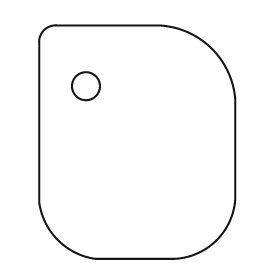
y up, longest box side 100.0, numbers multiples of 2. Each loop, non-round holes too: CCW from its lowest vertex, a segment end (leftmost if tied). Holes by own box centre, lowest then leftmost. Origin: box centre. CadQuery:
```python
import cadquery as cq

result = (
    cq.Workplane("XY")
    .moveTo(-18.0, -50.0)
    .lineTo(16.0, -50.0)
    .threePointArc((34.0, -42.0), (42.0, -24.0))
    .lineTo(42.0, 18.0)
    .threePointArc((32.0, 40.0), (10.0, 50.0))
    .lineTo(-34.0, 50.0)
    .threePointArc((-40.0, 48.0), (-42.0, 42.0))
    .lineTo(-42.0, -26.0)
    .threePointArc((-34.0, -42.0), (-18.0, -50.0))
    .close()
    .moveTo(-22.0, 24.0)
    .circle(6.0)
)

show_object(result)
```